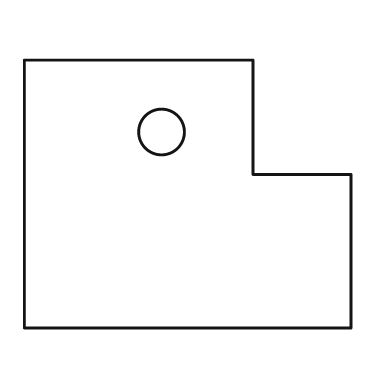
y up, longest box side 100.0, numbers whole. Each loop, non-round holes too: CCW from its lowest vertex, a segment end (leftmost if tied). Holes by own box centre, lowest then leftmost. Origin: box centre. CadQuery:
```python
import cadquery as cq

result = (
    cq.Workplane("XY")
    .moveTo(-50.0, -41.0)
    .lineTo(50.0, -41.0)
    .lineTo(50.0, 6.0)
    .lineTo(20.0, 6.0)
    .lineTo(20.0, 41.0)
    .lineTo(-50.0, 41.0)
    .close()
    .moveTo(-8.0, 19.0)
    .circle(7.0)
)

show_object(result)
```